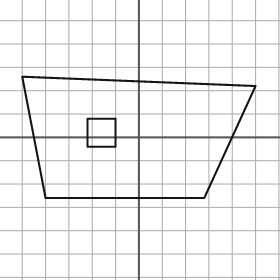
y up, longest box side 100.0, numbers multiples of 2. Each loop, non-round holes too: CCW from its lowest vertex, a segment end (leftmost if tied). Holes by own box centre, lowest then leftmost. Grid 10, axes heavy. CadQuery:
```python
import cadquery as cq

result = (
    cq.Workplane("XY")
    .moveTo(-40.0, -26.0)
    .lineTo(28.0, -26.0)
    .lineTo(50.0, 22.0)
    .lineTo(-50.0, 26.0)
    .close()
    .moveTo(-22.0, -4.0)
    .lineTo(-10.0, -4.0)
    .lineTo(-10.0, 8.0)
    .lineTo(-22.0, 8.0)
    .close()
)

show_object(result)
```